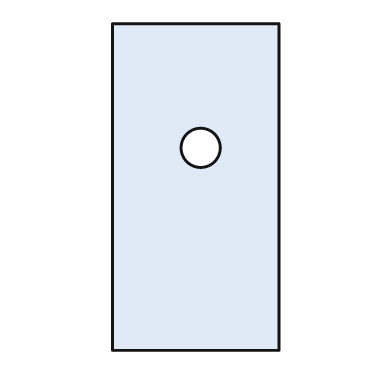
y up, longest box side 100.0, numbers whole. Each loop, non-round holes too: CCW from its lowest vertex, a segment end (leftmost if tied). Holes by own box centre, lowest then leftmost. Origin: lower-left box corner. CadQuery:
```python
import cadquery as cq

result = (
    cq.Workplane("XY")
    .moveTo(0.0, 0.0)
    .lineTo(51.0, 0.0)
    .lineTo(51.0, 100.0)
    .lineTo(0.0, 100.0)
    .close()
    .moveTo(27.0, 62.0)
    .circle(6.0)
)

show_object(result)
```